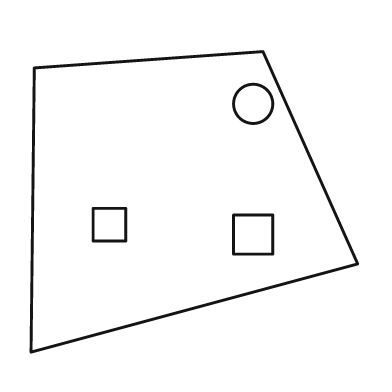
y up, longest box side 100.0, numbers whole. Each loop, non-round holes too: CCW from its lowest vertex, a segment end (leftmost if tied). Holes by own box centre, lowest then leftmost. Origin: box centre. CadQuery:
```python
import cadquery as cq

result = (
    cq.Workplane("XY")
    .moveTo(-50.0, -46.0)
    .lineTo(50.0, -19.0)
    .lineTo(21.0, 46.0)
    .lineTo(-49.0, 41.0)
    .close()
    .moveTo(12.0, -16.0)
    .lineTo(24.0, -16.0)
    .lineTo(24.0, -4.0)
    .lineTo(12.0, -4.0)
    .close()
    .moveTo(-31.0, -12.0)
    .lineTo(-21.0, -12.0)
    .lineTo(-21.0, -2.0)
    .lineTo(-31.0, -2.0)
    .close()
    .moveTo(18.0, 30.0)
    .circle(6.0)
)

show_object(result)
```